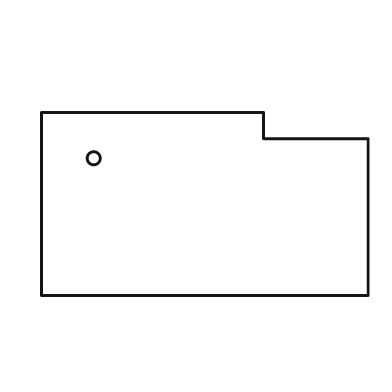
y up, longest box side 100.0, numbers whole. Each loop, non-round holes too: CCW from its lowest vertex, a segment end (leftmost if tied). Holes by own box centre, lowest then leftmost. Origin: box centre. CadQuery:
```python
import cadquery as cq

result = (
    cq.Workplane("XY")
    .moveTo(-50.0, -28.0)
    .lineTo(50.0, -28.0)
    .lineTo(50.0, 20.0)
    .lineTo(18.0, 20.0)
    .lineTo(18.0, 28.0)
    .lineTo(-50.0, 28.0)
    .close()
    .moveTo(-34.0, 14.0)
    .circle(2.0)
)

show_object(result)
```